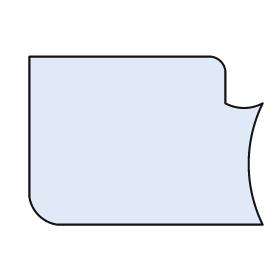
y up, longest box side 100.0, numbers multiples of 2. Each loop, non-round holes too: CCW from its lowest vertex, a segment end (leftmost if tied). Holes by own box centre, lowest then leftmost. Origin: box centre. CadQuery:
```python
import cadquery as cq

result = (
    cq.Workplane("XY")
    .moveTo(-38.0, -36.0)
    .lineTo(50.0, -36.0)
    .threePointArc((44.0, -10.0), (50.0, 16.0))
    .threePointArc((42.0, 14.0), (34.0, 16.0))
    .lineTo(34.0, 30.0)
    .threePointArc((32.0, 34.0), (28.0, 36.0))
    .lineTo(-50.0, 36.0)
    .lineTo(-50.0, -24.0)
    .threePointArc((-46.0, -32.0), (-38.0, -36.0))
    .close()
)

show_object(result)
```